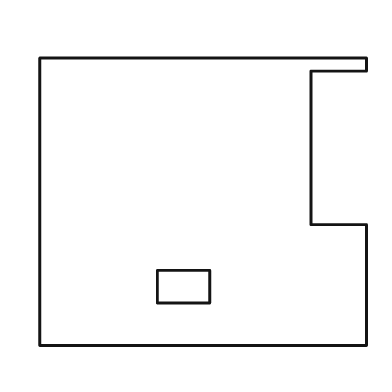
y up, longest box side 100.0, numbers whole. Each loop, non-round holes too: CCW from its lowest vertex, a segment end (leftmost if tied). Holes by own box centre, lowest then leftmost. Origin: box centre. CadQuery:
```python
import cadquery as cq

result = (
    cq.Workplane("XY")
    .moveTo(-50.0, -44.0)
    .lineTo(50.0, -44.0)
    .lineTo(50.0, -7.0)
    .lineTo(33.0, -7.0)
    .lineTo(33.0, 40.0)
    .lineTo(50.0, 40.0)
    .lineTo(50.0, 44.0)
    .lineTo(-50.0, 44.0)
    .close()
    .moveTo(-14.0, -31.0)
    .lineTo(2.0, -31.0)
    .lineTo(2.0, -21.0)
    .lineTo(-14.0, -21.0)
    .close()
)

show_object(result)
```